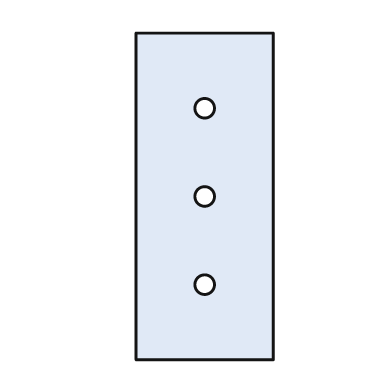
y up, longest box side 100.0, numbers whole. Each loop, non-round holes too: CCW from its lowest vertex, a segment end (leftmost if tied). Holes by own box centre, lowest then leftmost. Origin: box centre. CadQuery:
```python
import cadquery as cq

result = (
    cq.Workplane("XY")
    .moveTo(-21.0, -50.0)
    .lineTo(21.0, -50.0)
    .lineTo(21.0, 50.0)
    .lineTo(-21.0, 50.0)
    .close()
    .moveTo(0.0, -27.0)
    .circle(3.0)
    .moveTo(0.0, 0.0)
    .circle(3.0)
    .moveTo(0.0, 27.0)
    .circle(3.0)
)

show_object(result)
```